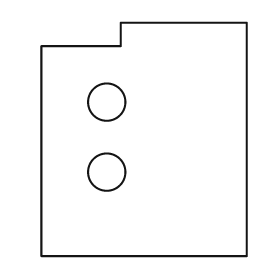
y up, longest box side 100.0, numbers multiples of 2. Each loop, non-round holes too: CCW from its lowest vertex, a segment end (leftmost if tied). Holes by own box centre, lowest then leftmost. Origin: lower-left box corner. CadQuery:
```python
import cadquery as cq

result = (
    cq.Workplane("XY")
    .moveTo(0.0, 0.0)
    .lineTo(88.0, 0.0)
    .lineTo(88.0, 100.0)
    .lineTo(34.0, 100.0)
    .lineTo(34.0, 90.0)
    .lineTo(0.0, 90.0)
    .close()
    .moveTo(28.0, 36.0)
    .circle(8.0)
    .moveTo(28.0, 66.0)
    .circle(8.0)
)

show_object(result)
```